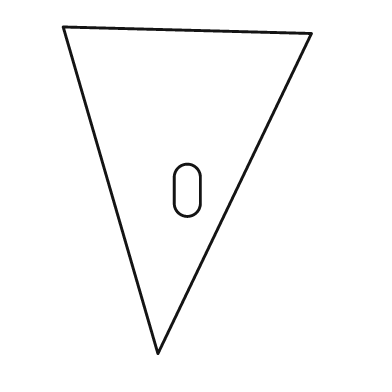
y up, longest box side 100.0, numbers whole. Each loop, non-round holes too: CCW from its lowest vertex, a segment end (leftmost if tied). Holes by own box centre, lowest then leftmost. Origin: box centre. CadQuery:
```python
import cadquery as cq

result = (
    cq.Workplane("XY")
    .moveTo(-9.0, -50.0)
    .lineTo(38.0, 48.0)
    .lineTo(-38.0, 50.0)
    .close()
    .moveTo(-4.0, -4.0)
    .threePointArc((0.0, -8.0), (4.0, -4.0))
    .lineTo(4.0, 4.0)
    .threePointArc((0.0, 8.0), (-4.0, 4.0))
    .close()
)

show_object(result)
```